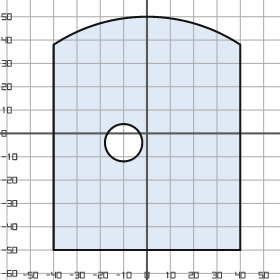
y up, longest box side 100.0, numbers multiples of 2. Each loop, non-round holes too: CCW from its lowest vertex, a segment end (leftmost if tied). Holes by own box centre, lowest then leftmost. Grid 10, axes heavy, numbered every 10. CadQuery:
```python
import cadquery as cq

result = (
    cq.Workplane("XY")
    .moveTo(-40.0, -50.0)
    .lineTo(40.0, -50.0)
    .lineTo(40.0, 38.0)
    .threePointArc((0.0, 50.0), (-40.0, 38.0))
    .close()
    .moveTo(-10.0, -4.0)
    .circle(8.0)
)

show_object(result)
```